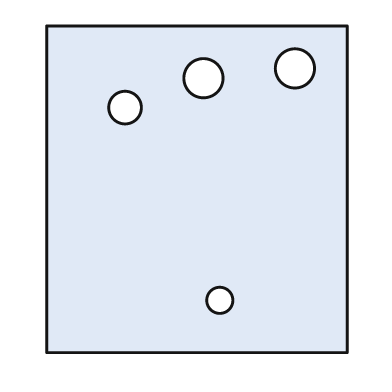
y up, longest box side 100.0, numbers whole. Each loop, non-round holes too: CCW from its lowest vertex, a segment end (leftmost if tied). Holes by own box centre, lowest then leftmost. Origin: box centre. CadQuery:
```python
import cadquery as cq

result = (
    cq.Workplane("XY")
    .moveTo(-46.0, -50.0)
    .lineTo(46.0, -50.0)
    .lineTo(46.0, 50.0)
    .lineTo(-46.0, 50.0)
    .close()
    .moveTo(7.0, -34.0)
    .circle(4.0)
    .moveTo(-22.0, 25.0)
    .circle(5.0)
    .moveTo(2.0, 34.0)
    .circle(6.0)
    .moveTo(30.0, 37.0)
    .circle(6.0)
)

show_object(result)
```